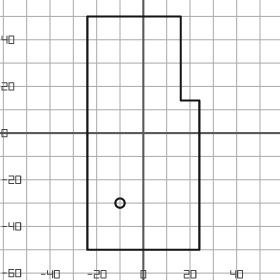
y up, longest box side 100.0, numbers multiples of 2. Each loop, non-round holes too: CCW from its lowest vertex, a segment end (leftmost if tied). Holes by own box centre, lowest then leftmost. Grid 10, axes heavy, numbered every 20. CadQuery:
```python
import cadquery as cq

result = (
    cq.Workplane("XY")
    .moveTo(-24.0, -50.0)
    .lineTo(24.0, -50.0)
    .lineTo(24.0, 14.0)
    .lineTo(16.0, 14.0)
    .lineTo(16.0, 50.0)
    .lineTo(-24.0, 50.0)
    .close()
    .moveTo(-10.0, -30.0)
    .circle(2.0)
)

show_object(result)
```